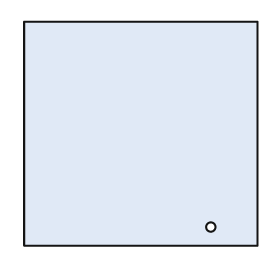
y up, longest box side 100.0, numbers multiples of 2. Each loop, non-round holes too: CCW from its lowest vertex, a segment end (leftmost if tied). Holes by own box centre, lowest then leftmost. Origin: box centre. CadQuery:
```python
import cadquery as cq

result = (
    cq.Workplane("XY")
    .moveTo(-50.0, -48.0)
    .lineTo(50.0, -48.0)
    .lineTo(50.0, 48.0)
    .lineTo(-50.0, 48.0)
    .close()
    .moveTo(30.0, -40.0)
    .circle(2.0)
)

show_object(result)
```